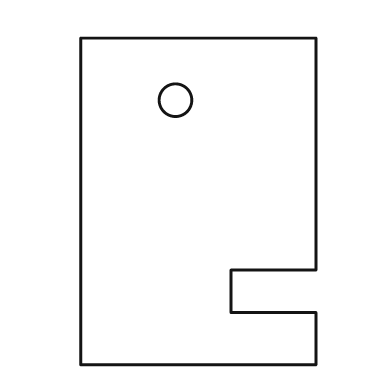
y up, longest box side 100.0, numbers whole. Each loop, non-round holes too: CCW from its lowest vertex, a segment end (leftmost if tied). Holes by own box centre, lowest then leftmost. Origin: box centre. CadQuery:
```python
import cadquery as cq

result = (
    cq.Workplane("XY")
    .moveTo(-36.0, -50.0)
    .lineTo(36.0, -50.0)
    .lineTo(36.0, -34.0)
    .lineTo(10.0, -34.0)
    .lineTo(10.0, -21.0)
    .lineTo(36.0, -21.0)
    .lineTo(36.0, 50.0)
    .lineTo(-36.0, 50.0)
    .close()
    .moveTo(-7.0, 31.0)
    .circle(5.0)
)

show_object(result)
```